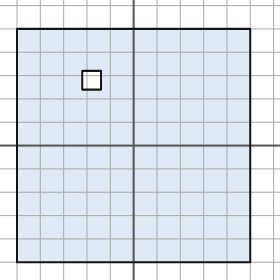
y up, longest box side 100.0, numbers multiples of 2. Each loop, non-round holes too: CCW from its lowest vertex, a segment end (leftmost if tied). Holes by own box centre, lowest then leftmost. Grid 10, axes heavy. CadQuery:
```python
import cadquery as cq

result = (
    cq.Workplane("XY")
    .moveTo(-50.0, -50.0)
    .lineTo(50.0, -50.0)
    .lineTo(50.0, 50.0)
    .lineTo(-50.0, 50.0)
    .close()
    .moveTo(-22.0, 24.0)
    .lineTo(-14.0, 24.0)
    .lineTo(-14.0, 32.0)
    .lineTo(-22.0, 32.0)
    .close()
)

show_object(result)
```